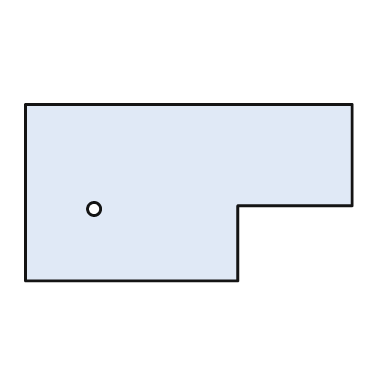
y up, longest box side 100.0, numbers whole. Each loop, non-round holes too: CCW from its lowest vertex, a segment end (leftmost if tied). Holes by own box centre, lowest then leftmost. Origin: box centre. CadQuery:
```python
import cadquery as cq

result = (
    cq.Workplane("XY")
    .moveTo(-50.0, -27.0)
    .lineTo(15.0, -27.0)
    .lineTo(15.0, -4.0)
    .lineTo(50.0, -4.0)
    .lineTo(50.0, 27.0)
    .lineTo(-50.0, 27.0)
    .close()
    .moveTo(-29.0, -5.0)
    .circle(2.0)
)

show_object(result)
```